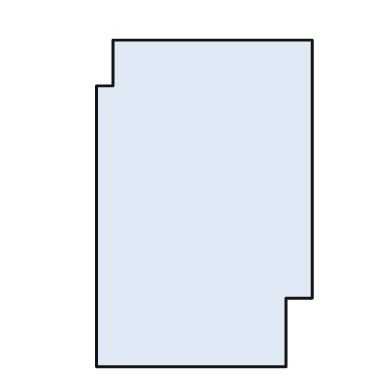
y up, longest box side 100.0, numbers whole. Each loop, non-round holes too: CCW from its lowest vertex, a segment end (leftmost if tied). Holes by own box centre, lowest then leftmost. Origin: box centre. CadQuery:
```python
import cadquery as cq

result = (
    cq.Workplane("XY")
    .moveTo(-33.0, -50.0)
    .lineTo(25.0, -50.0)
    .lineTo(25.0, -29.0)
    .lineTo(33.0, -29.0)
    .lineTo(33.0, 50.0)
    .lineTo(-28.0, 50.0)
    .lineTo(-28.0, 36.0)
    .lineTo(-33.0, 36.0)
    .close()
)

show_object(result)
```